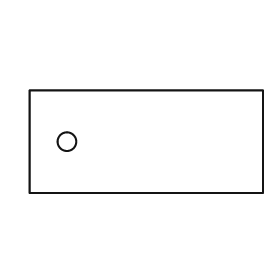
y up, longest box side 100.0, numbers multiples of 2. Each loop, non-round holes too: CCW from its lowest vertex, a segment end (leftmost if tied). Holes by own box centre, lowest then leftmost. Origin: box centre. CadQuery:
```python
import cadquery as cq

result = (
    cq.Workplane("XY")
    .moveTo(-50.0, -22.0)
    .lineTo(50.0, -22.0)
    .lineTo(50.0, 22.0)
    .lineTo(-50.0, 22.0)
    .close()
    .moveTo(-34.0, 0.0)
    .circle(4.0)
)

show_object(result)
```